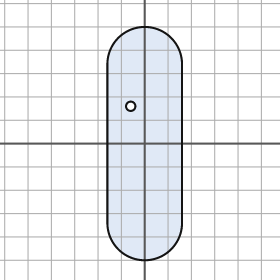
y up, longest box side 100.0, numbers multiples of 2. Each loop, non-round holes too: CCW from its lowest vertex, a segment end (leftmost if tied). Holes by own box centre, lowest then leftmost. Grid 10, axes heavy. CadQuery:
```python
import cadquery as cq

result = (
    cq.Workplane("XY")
    .moveTo(-16.0, -34.0)
    .threePointArc((0.0, -50.0), (16.0, -34.0))
    .lineTo(16.0, 34.0)
    .threePointArc((0.0, 50.0), (-16.0, 34.0))
    .close()
    .moveTo(-6.0, 16.0)
    .circle(2.0)
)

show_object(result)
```